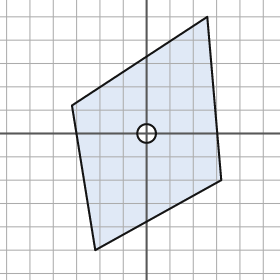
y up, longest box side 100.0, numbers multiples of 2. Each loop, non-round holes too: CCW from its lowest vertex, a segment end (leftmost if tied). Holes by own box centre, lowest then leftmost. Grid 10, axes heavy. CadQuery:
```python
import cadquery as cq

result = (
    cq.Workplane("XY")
    .moveTo(-22.0, -50.0)
    .lineTo(32.0, -20.0)
    .lineTo(26.0, 50.0)
    .lineTo(-32.0, 12.0)
    .close()
    .moveTo(0.0, 0.0)
    .circle(4.0)
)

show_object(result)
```